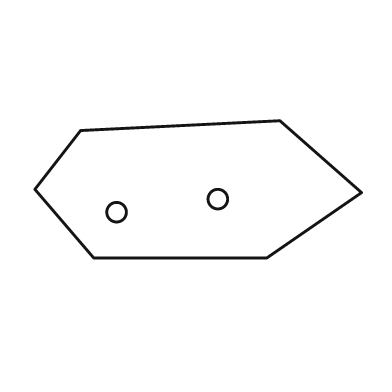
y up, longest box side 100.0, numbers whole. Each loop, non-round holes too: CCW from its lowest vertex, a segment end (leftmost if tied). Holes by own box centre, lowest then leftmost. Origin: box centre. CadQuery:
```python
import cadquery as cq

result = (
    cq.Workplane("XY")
    .moveTo(-32.0, -21.0)
    .lineTo(21.0, -21.0)
    .lineTo(50.0, -1.0)
    .lineTo(25.0, 21.0)
    .lineTo(-36.0, 18.0)
    .lineTo(-50.0, 0.0)
    .close()
    .moveTo(-25.0, -7.0)
    .circle(3.0)
    .moveTo(6.0, -3.0)
    .circle(3.0)
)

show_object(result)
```